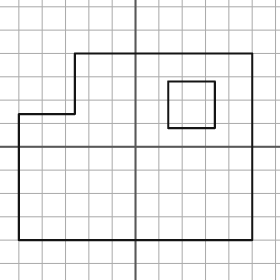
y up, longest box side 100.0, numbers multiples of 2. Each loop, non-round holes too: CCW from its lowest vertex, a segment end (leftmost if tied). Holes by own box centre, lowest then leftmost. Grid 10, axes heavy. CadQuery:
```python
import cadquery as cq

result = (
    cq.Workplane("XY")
    .moveTo(-50.0, -40.0)
    .lineTo(50.0, -40.0)
    .lineTo(50.0, 40.0)
    .lineTo(-26.0, 40.0)
    .lineTo(-26.0, 14.0)
    .lineTo(-50.0, 14.0)
    .close()
    .moveTo(14.0, 8.0)
    .lineTo(34.0, 8.0)
    .lineTo(34.0, 28.0)
    .lineTo(14.0, 28.0)
    .close()
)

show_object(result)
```